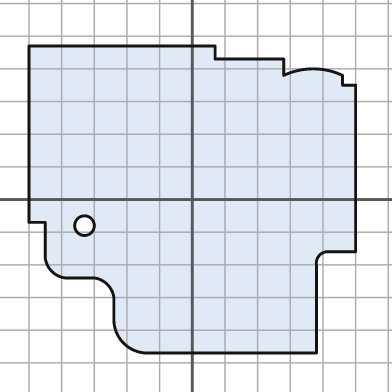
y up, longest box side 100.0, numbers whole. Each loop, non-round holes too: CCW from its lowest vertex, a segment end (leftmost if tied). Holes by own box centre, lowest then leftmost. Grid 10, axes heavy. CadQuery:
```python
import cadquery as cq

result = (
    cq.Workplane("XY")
    .moveTo(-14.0, -47.0)
    .lineTo(38.0, -47.0)
    .lineTo(38.0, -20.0)
    .threePointArc((39.0, -17.0), (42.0, -16.0))
    .lineTo(50.0, -16.0)
    .lineTo(50.0, 35.0)
    .lineTo(46.0, 35.0)
    .lineTo(46.0, 38.0)
    .threePointArc((37.0, 40.0), (28.0, 38.0))
    .lineTo(28.0, 43.0)
    .lineTo(7.0, 43.0)
    .lineTo(7.0, 47.0)
    .lineTo(-50.0, 47.0)
    .lineTo(-50.0, -7.0)
    .lineTo(-45.0, -7.0)
    .lineTo(-45.0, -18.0)
    .threePointArc((-43.0, -22.0), (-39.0, -24.0))
    .lineTo(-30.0, -24.0)
    .threePointArc((-26.0, -26.0), (-24.0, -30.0))
    .lineTo(-24.0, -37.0)
    .threePointArc((-21.0, -44.0), (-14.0, -47.0))
    .close()
    .moveTo(-33.0, -8.0)
    .circle(3.0)
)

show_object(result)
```